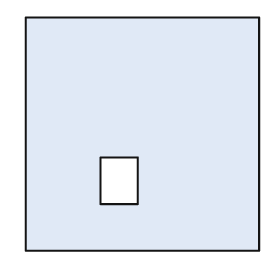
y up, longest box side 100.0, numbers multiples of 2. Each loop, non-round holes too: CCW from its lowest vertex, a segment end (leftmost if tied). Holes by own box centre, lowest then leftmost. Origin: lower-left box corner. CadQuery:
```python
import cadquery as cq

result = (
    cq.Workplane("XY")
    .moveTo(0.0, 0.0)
    .lineTo(100.0, 0.0)
    .lineTo(100.0, 100.0)
    .lineTo(0.0, 100.0)
    .close()
    .moveTo(32.0, 20.0)
    .lineTo(48.0, 20.0)
    .lineTo(48.0, 40.0)
    .lineTo(32.0, 40.0)
    .close()
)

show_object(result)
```